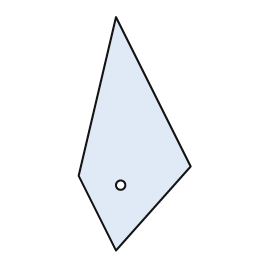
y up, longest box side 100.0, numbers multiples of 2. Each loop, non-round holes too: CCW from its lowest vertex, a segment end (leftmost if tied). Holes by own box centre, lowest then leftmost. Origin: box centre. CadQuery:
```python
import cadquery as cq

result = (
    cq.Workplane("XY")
    .moveTo(-8.0, -50.0)
    .lineTo(24.0, -14.0)
    .lineTo(-8.0, 50.0)
    .lineTo(-24.0, -18.0)
    .close()
    .moveTo(-6.0, -22.0)
    .circle(2.0)
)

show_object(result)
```